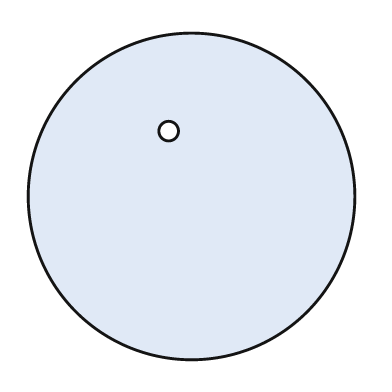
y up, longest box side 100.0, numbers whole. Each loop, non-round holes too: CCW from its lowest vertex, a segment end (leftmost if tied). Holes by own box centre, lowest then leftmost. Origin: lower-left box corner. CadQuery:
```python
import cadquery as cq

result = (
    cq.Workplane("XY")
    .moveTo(50.0, 50.0)
    .circle(50.0)
    .moveTo(43.0, 70.0)
    .circle(3.0)
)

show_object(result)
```